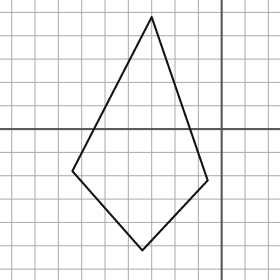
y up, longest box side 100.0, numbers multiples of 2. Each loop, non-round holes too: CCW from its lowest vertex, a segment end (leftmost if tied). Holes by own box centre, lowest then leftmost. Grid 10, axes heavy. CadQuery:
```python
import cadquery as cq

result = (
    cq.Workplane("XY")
    .moveTo(-34.0, -52.0)
    .lineTo(-6.0, -22.0)
    .lineTo(-30.0, 48.0)
    .lineTo(-64.0, -18.0)
    .close()
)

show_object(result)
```